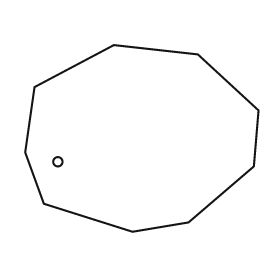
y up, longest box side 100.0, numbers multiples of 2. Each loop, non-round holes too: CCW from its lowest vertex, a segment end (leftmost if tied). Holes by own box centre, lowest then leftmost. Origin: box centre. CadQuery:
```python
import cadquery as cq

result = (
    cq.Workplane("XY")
    .moveTo(-4.0, -40.0)
    .lineTo(20.0, -36.0)
    .lineTo(48.0, -12.0)
    .lineTo(50.0, 12.0)
    .lineTo(24.0, 36.0)
    .lineTo(-12.0, 40.0)
    .lineTo(-46.0, 22.0)
    .lineTo(-50.0, -6.0)
    .lineTo(-42.0, -28.0)
    .close()
    .moveTo(-36.0, -10.0)
    .circle(2.0)
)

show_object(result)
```